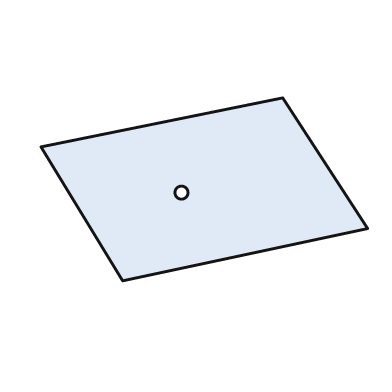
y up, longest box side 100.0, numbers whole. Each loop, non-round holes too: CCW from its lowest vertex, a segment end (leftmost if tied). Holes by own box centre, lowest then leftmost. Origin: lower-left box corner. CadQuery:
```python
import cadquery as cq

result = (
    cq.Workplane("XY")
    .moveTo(25.0, 0.0)
    .lineTo(100.0, 16.0)
    .lineTo(74.0, 56.0)
    .lineTo(0.0, 41.0)
    .close()
    .moveTo(43.0, 27.0)
    .circle(2.0)
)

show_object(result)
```